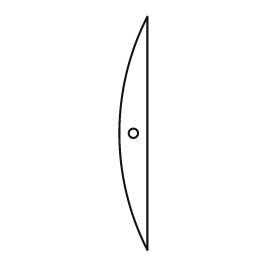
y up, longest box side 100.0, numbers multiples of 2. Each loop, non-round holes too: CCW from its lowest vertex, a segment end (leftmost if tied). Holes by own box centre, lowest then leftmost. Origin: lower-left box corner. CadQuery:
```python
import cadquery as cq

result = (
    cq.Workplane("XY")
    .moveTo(12.0, 0.0)
    .lineTo(12.0, 100.0)
    .threePointArc((0.0, 50.0), (12.0, 0.0))
    .close()
    .moveTo(6.0, 50.0)
    .circle(2.0)
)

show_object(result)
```